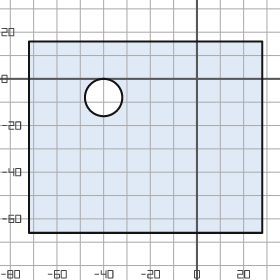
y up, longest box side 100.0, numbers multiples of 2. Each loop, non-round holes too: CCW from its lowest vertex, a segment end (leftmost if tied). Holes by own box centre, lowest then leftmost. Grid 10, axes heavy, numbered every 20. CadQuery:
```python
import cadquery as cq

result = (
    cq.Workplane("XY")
    .moveTo(-72.0, -66.0)
    .lineTo(28.0, -66.0)
    .lineTo(28.0, 16.0)
    .lineTo(-72.0, 16.0)
    .close()
    .moveTo(-40.0, -8.0)
    .circle(8.0)
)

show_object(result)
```